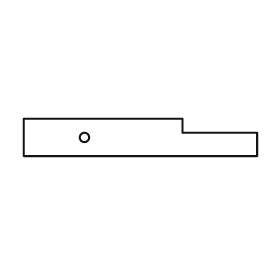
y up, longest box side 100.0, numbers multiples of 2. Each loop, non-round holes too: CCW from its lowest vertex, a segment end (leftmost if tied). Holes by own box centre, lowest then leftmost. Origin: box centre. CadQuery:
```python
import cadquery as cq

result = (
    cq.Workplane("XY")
    .moveTo(-50.0, -8.0)
    .lineTo(50.0, -8.0)
    .lineTo(50.0, 2.0)
    .lineTo(18.0, 2.0)
    .lineTo(18.0, 8.0)
    .lineTo(-50.0, 8.0)
    .close()
    .moveTo(-24.0, 0.0)
    .circle(2.0)
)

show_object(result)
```